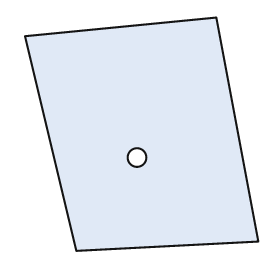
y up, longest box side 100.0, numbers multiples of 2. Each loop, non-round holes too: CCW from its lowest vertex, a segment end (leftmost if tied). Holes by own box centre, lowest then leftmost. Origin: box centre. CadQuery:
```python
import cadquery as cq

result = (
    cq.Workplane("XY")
    .moveTo(-28.0, -50.0)
    .lineTo(50.0, -46.0)
    .lineTo(32.0, 50.0)
    .lineTo(-50.0, 42.0)
    .close()
    .moveTo(-2.0, -10.0)
    .circle(4.0)
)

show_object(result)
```